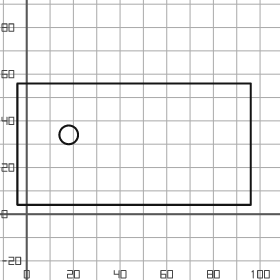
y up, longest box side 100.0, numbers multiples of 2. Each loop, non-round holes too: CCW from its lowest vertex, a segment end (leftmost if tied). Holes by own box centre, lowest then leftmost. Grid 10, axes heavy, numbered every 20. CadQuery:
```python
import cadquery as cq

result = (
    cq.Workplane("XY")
    .moveTo(-4.0, 4.0)
    .lineTo(96.0, 4.0)
    .lineTo(96.0, 56.0)
    .lineTo(-4.0, 56.0)
    .close()
    .moveTo(18.0, 34.0)
    .circle(4.0)
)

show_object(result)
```